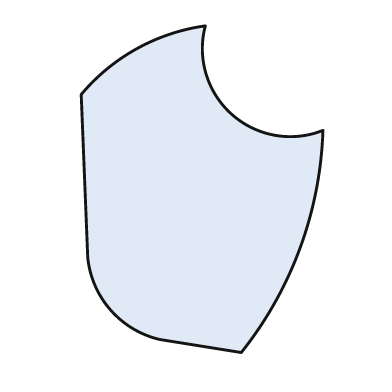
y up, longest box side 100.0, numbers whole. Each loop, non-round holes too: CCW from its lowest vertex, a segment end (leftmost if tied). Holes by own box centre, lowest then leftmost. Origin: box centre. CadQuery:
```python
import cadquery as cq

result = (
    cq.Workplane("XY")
    .moveTo(12.0, -50.0)
    .threePointArc((30.0, -18.0), (37.0, 18.0))
    .threePointArc((9.0, 23.0), (1.0, 50.0))
    .threePointArc((-20.0, 43.0), (-37.0, 29.0))
    .lineTo(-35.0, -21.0)
    .threePointArc((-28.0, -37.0), (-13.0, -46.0))
    .close()
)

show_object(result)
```